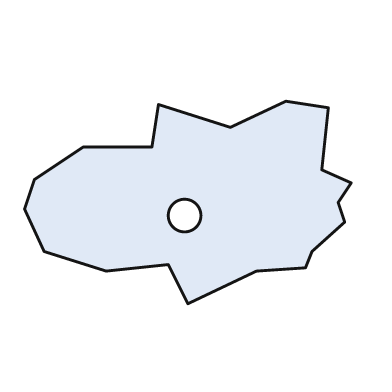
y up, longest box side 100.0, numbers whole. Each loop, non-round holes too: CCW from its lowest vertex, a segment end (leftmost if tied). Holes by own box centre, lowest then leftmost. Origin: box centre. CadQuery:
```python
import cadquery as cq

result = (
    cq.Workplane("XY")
    .moveTo(0.0, -31.0)
    .lineTo(21.0, -21.0)
    .lineTo(36.0, -20.0)
    .lineTo(38.0, -15.0)
    .lineTo(48.0, -6.0)
    .lineTo(46.0, 0.0)
    .lineTo(50.0, 6.0)
    .lineTo(41.0, 10.0)
    .lineTo(43.0, 29.0)
    .lineTo(30.0, 31.0)
    .lineTo(13.0, 23.0)
    .lineTo(-9.0, 30.0)
    .lineTo(-11.0, 17.0)
    .lineTo(-32.0, 17.0)
    .lineTo(-47.0, 7.0)
    .lineTo(-50.0, -2.0)
    .lineTo(-44.0, -15.0)
    .lineTo(-25.0, -21.0)
    .lineTo(-6.0, -19.0)
    .close()
    .moveTo(-1.0, -4.0)
    .circle(5.0)
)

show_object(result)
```